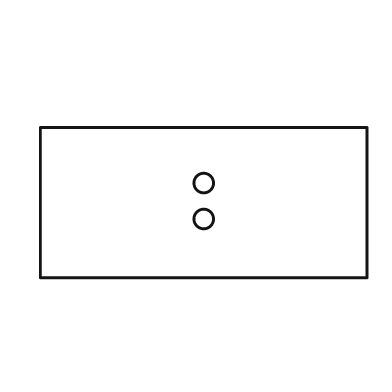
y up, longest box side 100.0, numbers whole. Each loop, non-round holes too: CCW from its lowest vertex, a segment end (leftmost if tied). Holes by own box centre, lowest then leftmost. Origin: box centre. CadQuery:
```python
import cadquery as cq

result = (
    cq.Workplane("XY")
    .moveTo(-50.0, -23.0)
    .lineTo(50.0, -23.0)
    .lineTo(50.0, 23.0)
    .lineTo(-50.0, 23.0)
    .close()
    .moveTo(0.0, -5.0)
    .circle(3.0)
    .moveTo(0.0, 6.0)
    .circle(3.0)
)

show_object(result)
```